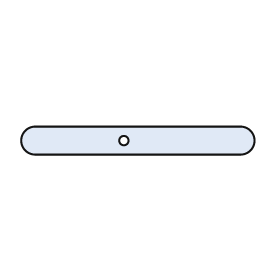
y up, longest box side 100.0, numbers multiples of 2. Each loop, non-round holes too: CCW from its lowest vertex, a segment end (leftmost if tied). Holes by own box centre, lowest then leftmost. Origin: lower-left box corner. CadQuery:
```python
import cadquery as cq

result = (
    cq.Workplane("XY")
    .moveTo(6.0, 0.0)
    .lineTo(94.0, 0.0)
    .threePointArc((100.0, 6.0), (94.0, 12.0))
    .lineTo(6.0, 12.0)
    .threePointArc((0.0, 6.0), (6.0, 0.0))
    .close()
    .moveTo(44.0, 6.0)
    .circle(2.0)
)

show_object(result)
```